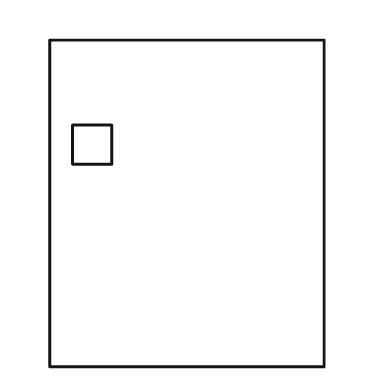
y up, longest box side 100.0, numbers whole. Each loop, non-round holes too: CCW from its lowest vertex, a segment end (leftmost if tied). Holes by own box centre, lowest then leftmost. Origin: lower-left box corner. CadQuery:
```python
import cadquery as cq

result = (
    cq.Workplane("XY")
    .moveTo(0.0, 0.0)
    .lineTo(84.0, 0.0)
    .lineTo(84.0, 100.0)
    .lineTo(0.0, 100.0)
    .close()
    .moveTo(7.0, 62.0)
    .lineTo(19.0, 62.0)
    .lineTo(19.0, 74.0)
    .lineTo(7.0, 74.0)
    .close()
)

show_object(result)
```